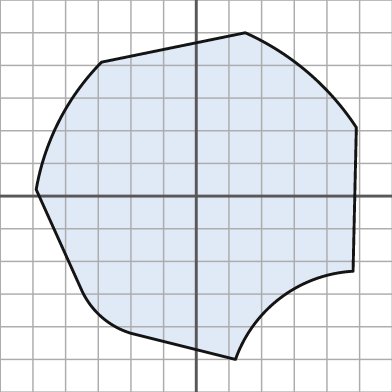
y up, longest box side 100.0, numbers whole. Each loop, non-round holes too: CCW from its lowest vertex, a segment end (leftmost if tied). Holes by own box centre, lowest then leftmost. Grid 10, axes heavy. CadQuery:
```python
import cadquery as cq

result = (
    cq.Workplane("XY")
    .moveTo(12.0, -50.0)
    .threePointArc((26.0, -31.0), (48.0, -23.0))
    .lineTo(49.0, 21.0)
    .threePointArc((34.0, 38.0), (15.0, 50.0))
    .lineTo(-29.0, 41.0)
    .threePointArc((-42.0, 23.0), (-49.0, 2.0))
    .lineTo(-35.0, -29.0)
    .threePointArc((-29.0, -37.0), (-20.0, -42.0))
    .close()
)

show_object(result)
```